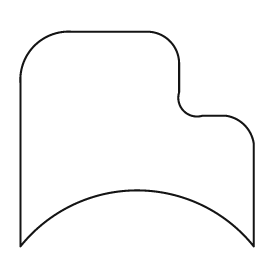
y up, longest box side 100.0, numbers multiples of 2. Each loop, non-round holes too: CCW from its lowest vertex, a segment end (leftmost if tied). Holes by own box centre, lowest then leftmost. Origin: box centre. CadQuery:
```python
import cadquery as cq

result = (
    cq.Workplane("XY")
    .moveTo(-50.0, -46.0)
    .threePointArc((0.0, -22.0), (50.0, -46.0))
    .lineTo(50.0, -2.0)
    .threePointArc((46.0, 6.0), (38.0, 10.0))
    .lineTo(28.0, 10.0)
    .threePointArc((20.0, 12.0), (18.0, 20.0))
    .lineTo(18.0, 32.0)
    .threePointArc((14.0, 42.0), (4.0, 46.0))
    .lineTo(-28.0, 46.0)
    .threePointArc((-44.0, 40.0), (-50.0, 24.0))
    .close()
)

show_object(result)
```